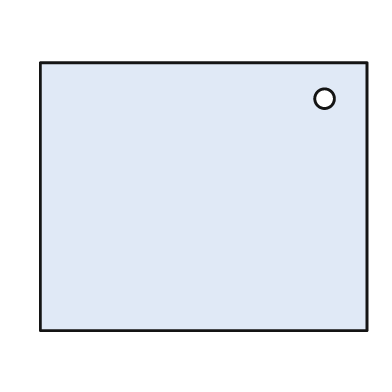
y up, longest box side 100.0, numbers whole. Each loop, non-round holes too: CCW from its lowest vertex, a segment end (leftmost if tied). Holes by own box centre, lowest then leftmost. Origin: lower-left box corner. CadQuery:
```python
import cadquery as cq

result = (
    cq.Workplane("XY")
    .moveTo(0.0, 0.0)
    .lineTo(100.0, 0.0)
    .lineTo(100.0, 82.0)
    .lineTo(0.0, 82.0)
    .close()
    .moveTo(87.0, 71.0)
    .circle(3.0)
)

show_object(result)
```